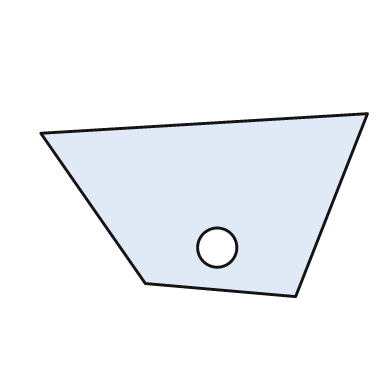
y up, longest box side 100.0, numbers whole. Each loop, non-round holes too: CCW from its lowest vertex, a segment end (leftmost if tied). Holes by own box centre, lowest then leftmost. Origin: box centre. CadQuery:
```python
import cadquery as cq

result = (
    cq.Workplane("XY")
    .moveTo(28.0, -28.0)
    .lineTo(50.0, 28.0)
    .lineTo(-50.0, 22.0)
    .lineTo(-18.0, -24.0)
    .close()
    .moveTo(4.0, -13.0)
    .circle(6.0)
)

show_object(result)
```